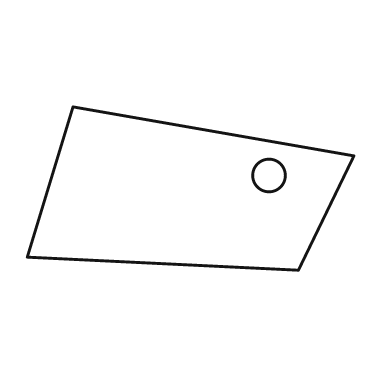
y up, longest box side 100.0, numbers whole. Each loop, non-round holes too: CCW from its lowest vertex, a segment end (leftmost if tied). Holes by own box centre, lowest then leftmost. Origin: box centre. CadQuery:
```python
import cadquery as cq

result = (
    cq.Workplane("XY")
    .moveTo(33.0, -25.0)
    .lineTo(50.0, 10.0)
    .lineTo(-36.0, 25.0)
    .lineTo(-50.0, -21.0)
    .close()
    .moveTo(24.0, 4.0)
    .circle(5.0)
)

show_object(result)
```